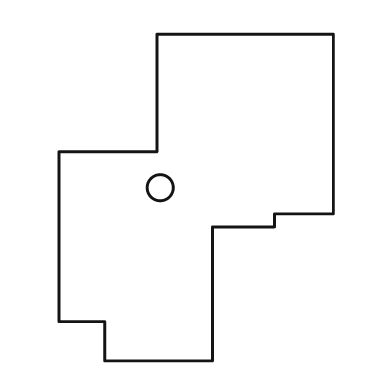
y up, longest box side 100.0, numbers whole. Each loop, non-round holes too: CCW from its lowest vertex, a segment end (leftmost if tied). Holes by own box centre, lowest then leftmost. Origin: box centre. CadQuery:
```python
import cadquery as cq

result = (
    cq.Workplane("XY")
    .moveTo(-28.0, -50.0)
    .lineTo(5.0, -50.0)
    .lineTo(5.0, -9.0)
    .lineTo(24.0, -9.0)
    .lineTo(24.0, -5.0)
    .lineTo(42.0, -5.0)
    .lineTo(42.0, 50.0)
    .lineTo(-12.0, 50.0)
    .lineTo(-12.0, 14.0)
    .lineTo(-42.0, 14.0)
    .lineTo(-42.0, -38.0)
    .lineTo(-28.0, -38.0)
    .close()
    .moveTo(-11.0, 3.0)
    .circle(4.0)
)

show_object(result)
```